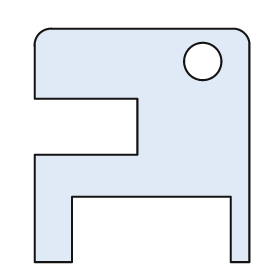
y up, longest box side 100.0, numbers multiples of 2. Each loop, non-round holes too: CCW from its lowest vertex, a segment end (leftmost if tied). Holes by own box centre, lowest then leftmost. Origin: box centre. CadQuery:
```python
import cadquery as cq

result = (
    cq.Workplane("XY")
    .moveTo(-46.0, -50.0)
    .lineTo(-30.0, -50.0)
    .lineTo(-30.0, -22.0)
    .lineTo(38.0, -22.0)
    .lineTo(38.0, -50.0)
    .lineTo(46.0, -50.0)
    .lineTo(46.0, 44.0)
    .threePointArc((44.0, 48.0), (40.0, 50.0))
    .lineTo(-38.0, 50.0)
    .threePointArc((-44.0, 48.0), (-46.0, 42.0))
    .lineTo(-46.0, 20.0)
    .lineTo(-2.0, 20.0)
    .lineTo(-2.0, -4.0)
    .lineTo(-46.0, -4.0)
    .close()
    .moveTo(26.0, 36.0)
    .circle(8.0)
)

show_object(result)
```